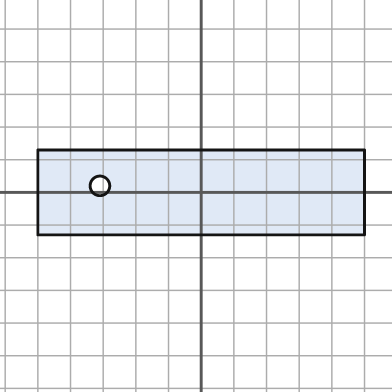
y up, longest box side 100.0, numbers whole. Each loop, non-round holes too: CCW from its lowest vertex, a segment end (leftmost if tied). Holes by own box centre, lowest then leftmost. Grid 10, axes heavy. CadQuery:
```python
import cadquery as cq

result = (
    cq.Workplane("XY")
    .moveTo(-50.0, -13.0)
    .lineTo(50.0, -13.0)
    .lineTo(50.0, 13.0)
    .lineTo(-50.0, 13.0)
    .close()
    .moveTo(-31.0, 2.0)
    .circle(3.0)
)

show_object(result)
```